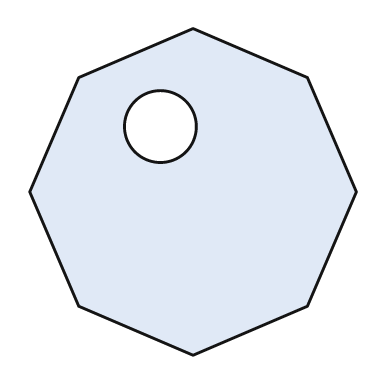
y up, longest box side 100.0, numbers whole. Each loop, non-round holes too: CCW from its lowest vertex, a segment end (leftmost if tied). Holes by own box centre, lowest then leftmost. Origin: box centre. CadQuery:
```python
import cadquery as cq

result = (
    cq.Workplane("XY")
    .moveTo(0.0, -50.0)
    .lineTo(35.0, -35.0)
    .lineTo(50.0, 0.0)
    .lineTo(35.0, 35.0)
    .lineTo(0.0, 50.0)
    .lineTo(-35.0, 35.0)
    .lineTo(-50.0, 0.0)
    .lineTo(-35.0, -35.0)
    .close()
    .moveTo(-10.0, 20.0)
    .circle(11.0)
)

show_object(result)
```